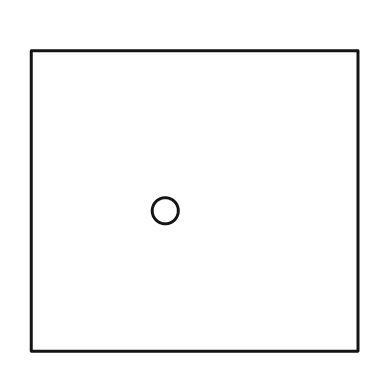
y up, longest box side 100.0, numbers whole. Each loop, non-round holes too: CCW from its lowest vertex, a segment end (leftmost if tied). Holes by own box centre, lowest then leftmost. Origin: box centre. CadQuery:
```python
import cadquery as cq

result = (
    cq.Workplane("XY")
    .moveTo(-50.0, -46.0)
    .lineTo(50.0, -46.0)
    .lineTo(50.0, 46.0)
    .lineTo(-50.0, 46.0)
    .close()
    .moveTo(-9.0, -3.0)
    .circle(4.0)
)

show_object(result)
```